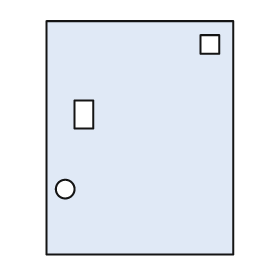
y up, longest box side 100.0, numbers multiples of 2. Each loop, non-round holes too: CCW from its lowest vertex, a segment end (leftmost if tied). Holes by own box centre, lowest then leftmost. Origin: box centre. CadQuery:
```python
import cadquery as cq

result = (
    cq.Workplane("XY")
    .moveTo(-40.0, -50.0)
    .lineTo(40.0, -50.0)
    .lineTo(40.0, 50.0)
    .lineTo(-40.0, 50.0)
    .close()
    .moveTo(-32.0, -22.0)
    .circle(4.0)
    .moveTo(-28.0, 4.0)
    .lineTo(-20.0, 4.0)
    .lineTo(-20.0, 16.0)
    .lineTo(-28.0, 16.0)
    .close()
    .moveTo(26.0, 36.0)
    .lineTo(34.0, 36.0)
    .lineTo(34.0, 44.0)
    .lineTo(26.0, 44.0)
    .close()
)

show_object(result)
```